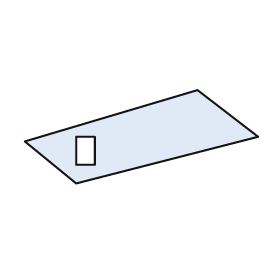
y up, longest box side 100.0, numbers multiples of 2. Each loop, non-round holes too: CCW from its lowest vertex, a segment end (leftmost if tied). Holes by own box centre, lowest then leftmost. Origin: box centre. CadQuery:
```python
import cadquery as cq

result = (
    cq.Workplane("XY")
    .moveTo(-28.0, -20.0)
    .lineTo(50.0, 0.0)
    .lineTo(24.0, 20.0)
    .lineTo(-50.0, -2.0)
    .close()
    .moveTo(-28.0, -12.0)
    .lineTo(-20.0, -12.0)
    .lineTo(-20.0, 0.0)
    .lineTo(-28.0, 0.0)
    .close()
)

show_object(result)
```